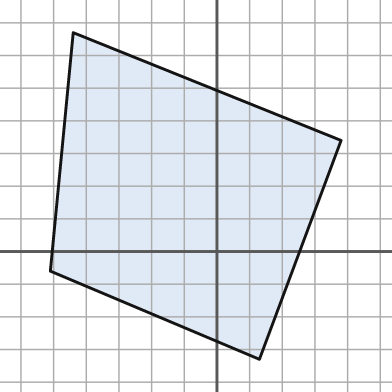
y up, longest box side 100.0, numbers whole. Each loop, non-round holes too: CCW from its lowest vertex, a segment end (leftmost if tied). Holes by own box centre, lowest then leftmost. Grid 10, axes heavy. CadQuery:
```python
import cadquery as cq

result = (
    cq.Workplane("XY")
    .moveTo(13.0, -33.0)
    .lineTo(38.0, 34.0)
    .lineTo(-44.0, 67.0)
    .lineTo(-51.0, -6.0)
    .close()
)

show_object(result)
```